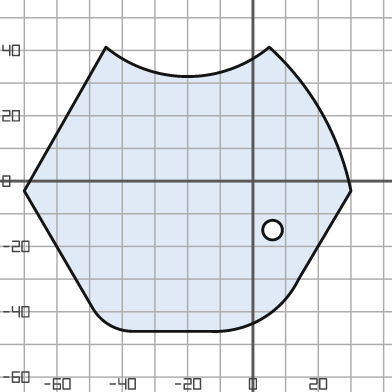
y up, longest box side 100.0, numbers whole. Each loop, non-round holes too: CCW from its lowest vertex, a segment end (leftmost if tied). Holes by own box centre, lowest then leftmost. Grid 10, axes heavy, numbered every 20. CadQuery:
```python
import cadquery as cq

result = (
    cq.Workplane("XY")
    .moveTo(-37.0, -46.0)
    .lineTo(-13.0, -46.0)
    .threePointArc((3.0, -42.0), (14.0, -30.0))
    .lineTo(30.0, -3.0)
    .threePointArc((21.0, 21.0), (5.0, 41.0))
    .threePointArc((-20.0, 32.0), (-45.0, 41.0))
    .lineTo(-70.0, -3.0)
    .lineTo(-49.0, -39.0)
    .threePointArc((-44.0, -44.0), (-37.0, -46.0))
    .close()
    .moveTo(6.0, -15.0)
    .circle(3.0)
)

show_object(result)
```